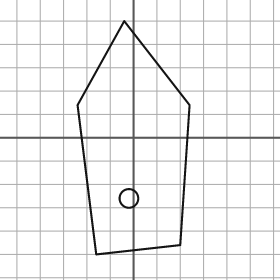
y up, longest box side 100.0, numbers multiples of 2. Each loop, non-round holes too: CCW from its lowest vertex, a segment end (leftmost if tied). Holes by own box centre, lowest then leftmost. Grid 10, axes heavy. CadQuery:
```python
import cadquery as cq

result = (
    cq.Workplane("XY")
    .moveTo(-16.0, -50.0)
    .lineTo(20.0, -46.0)
    .lineTo(24.0, 14.0)
    .lineTo(-4.0, 50.0)
    .lineTo(-24.0, 14.0)
    .close()
    .moveTo(-2.0, -26.0)
    .circle(4.0)
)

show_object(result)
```